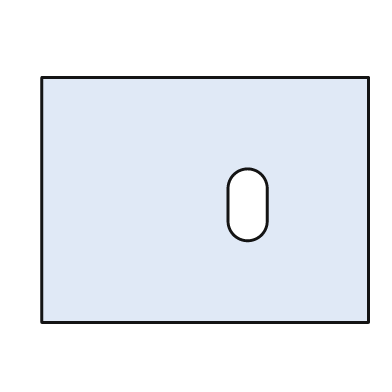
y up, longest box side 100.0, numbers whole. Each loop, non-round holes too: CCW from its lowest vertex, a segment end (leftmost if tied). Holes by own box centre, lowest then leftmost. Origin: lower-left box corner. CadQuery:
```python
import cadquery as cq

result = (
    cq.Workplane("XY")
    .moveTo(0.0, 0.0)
    .lineTo(100.0, 0.0)
    .lineTo(100.0, 75.0)
    .lineTo(0.0, 75.0)
    .close()
    .moveTo(57.0, 31.0)
    .threePointArc((63.0, 25.0), (69.0, 31.0))
    .lineTo(69.0, 41.0)
    .threePointArc((63.0, 47.0), (57.0, 41.0))
    .close()
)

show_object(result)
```